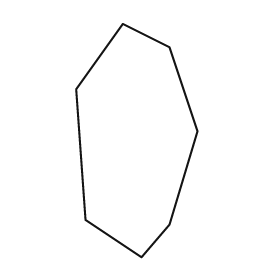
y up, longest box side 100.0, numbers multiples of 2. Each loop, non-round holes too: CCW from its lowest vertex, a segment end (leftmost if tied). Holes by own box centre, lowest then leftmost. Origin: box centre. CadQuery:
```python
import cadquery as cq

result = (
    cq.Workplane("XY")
    .moveTo(2.0, -50.0)
    .lineTo(14.0, -36.0)
    .lineTo(26.0, 4.0)
    .lineTo(14.0, 40.0)
    .lineTo(-6.0, 50.0)
    .lineTo(-26.0, 22.0)
    .lineTo(-22.0, -34.0)
    .close()
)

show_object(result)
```